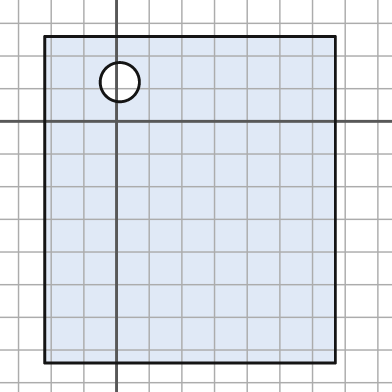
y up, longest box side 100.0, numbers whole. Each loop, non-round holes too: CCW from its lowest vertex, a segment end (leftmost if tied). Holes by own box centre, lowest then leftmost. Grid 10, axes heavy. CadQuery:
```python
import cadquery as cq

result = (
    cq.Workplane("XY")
    .moveTo(-22.0, -74.0)
    .lineTo(67.0, -74.0)
    .lineTo(67.0, 26.0)
    .lineTo(-22.0, 26.0)
    .close()
    .moveTo(1.0, 12.0)
    .circle(6.0)
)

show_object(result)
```